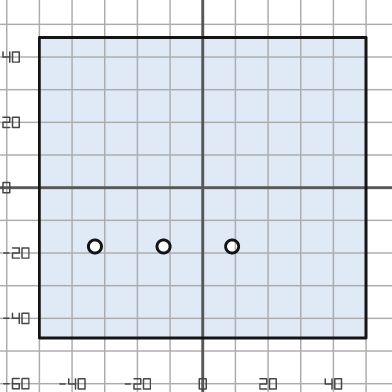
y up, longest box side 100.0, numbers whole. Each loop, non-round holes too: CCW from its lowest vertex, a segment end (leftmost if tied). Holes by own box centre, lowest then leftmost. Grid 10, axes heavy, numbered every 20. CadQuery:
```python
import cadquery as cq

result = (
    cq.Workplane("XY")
    .moveTo(-50.0, -46.0)
    .lineTo(50.0, -46.0)
    .lineTo(50.0, 46.0)
    .lineTo(-50.0, 46.0)
    .close()
    .moveTo(-33.0, -18.0)
    .circle(2.0)
    .moveTo(-12.0, -18.0)
    .circle(2.0)
    .moveTo(9.0, -18.0)
    .circle(2.0)
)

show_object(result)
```